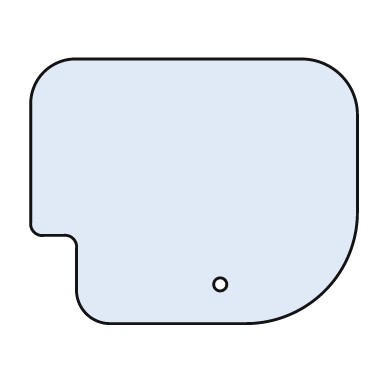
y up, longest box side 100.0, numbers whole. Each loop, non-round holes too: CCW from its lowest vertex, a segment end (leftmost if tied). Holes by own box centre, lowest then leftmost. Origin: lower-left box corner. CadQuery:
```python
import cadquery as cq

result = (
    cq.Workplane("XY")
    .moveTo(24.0, 0.0)
    .lineTo(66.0, 0.0)
    .threePointArc((90.0, 10.0), (100.0, 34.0))
    .lineTo(100.0, 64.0)
    .threePointArc((95.0, 76.0), (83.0, 81.0))
    .lineTo(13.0, 81.0)
    .threePointArc((4.0, 77.0), (0.0, 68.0))
    .lineTo(0.0, 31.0)
    .threePointArc((1.0, 28.0), (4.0, 27.0))
    .lineTo(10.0, 27.0)
    .threePointArc((13.0, 26.0), (14.0, 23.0))
    .lineTo(14.0, 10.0)
    .threePointArc((17.0, 3.0), (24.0, 0.0))
    .close()
    .moveTo(58.0, 12.0)
    .circle(2.0)
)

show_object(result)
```